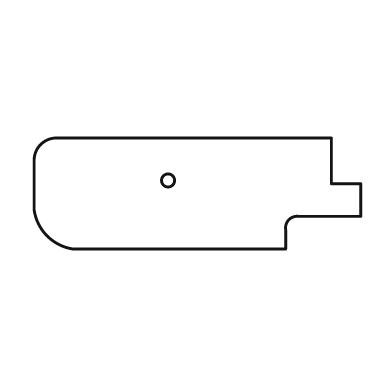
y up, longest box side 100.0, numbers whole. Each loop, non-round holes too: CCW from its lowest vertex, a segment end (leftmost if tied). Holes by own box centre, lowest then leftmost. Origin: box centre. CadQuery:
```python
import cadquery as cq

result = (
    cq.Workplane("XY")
    .moveTo(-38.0, -17.0)
    .lineTo(27.0, -17.0)
    .lineTo(27.0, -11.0)
    .threePointArc((28.0, -8.0), (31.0, -7.0))
    .lineTo(50.0, -7.0)
    .lineTo(50.0, 3.0)
    .lineTo(41.0, 3.0)
    .lineTo(41.0, 17.0)
    .lineTo(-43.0, 17.0)
    .threePointArc((-48.0, 15.0), (-50.0, 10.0))
    .lineTo(-50.0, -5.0)
    .threePointArc((-46.0, -13.0), (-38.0, -17.0))
    .close()
    .moveTo(-9.0, 4.0)
    .circle(2.0)
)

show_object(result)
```